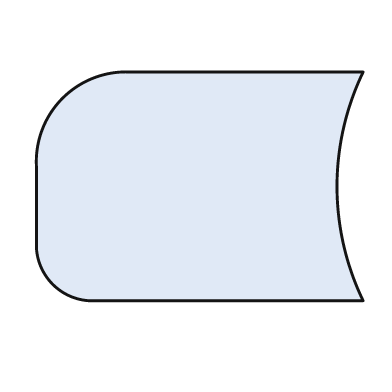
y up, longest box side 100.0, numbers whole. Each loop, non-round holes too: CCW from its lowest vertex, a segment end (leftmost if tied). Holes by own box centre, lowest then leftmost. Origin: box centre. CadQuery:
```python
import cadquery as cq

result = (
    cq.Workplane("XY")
    .moveTo(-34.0, -35.0)
    .lineTo(50.0, -35.0)
    .threePointArc((42.0, 0.0), (50.0, 35.0))
    .lineTo(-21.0, 35.0)
    .threePointArc((-42.0, 27.0), (-50.0, 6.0))
    .lineTo(-50.0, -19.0)
    .threePointArc((-45.0, -30.0), (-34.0, -35.0))
    .close()
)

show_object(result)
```